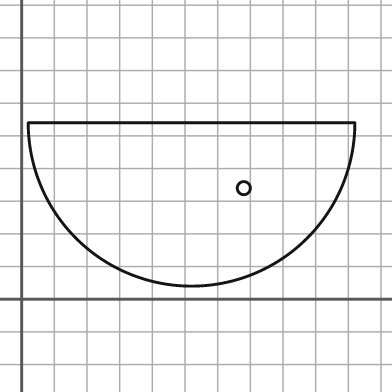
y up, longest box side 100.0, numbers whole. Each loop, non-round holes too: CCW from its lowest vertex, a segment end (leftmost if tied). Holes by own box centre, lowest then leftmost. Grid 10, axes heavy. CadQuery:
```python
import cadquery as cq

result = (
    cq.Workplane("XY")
    .moveTo(2.0, 54.0)
    .threePointArc((52.0, 4.0), (102.0, 54.0))
    .close()
    .moveTo(68.0, 34.0)
    .circle(2.0)
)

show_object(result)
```